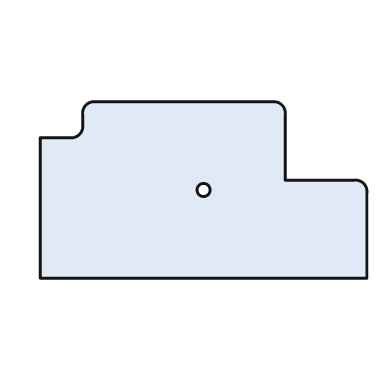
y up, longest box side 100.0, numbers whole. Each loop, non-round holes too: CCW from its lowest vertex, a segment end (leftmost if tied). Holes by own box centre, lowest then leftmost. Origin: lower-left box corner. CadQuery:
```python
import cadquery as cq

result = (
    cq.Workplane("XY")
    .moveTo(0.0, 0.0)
    .lineTo(100.0, 0.0)
    .lineTo(100.0, 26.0)
    .threePointArc((99.0, 29.0), (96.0, 30.0))
    .lineTo(75.0, 30.0)
    .lineTo(75.0, 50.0)
    .threePointArc((74.0, 53.0), (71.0, 54.0))
    .lineTo(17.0, 54.0)
    .threePointArc((14.0, 53.0), (13.0, 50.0))
    .lineTo(13.0, 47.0)
    .threePointArc((12.0, 44.0), (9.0, 43.0))
    .lineTo(0.0, 43.0)
    .close()
    .moveTo(50.0, 27.0)
    .circle(2.0)
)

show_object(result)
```